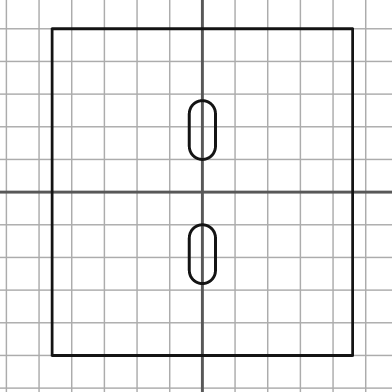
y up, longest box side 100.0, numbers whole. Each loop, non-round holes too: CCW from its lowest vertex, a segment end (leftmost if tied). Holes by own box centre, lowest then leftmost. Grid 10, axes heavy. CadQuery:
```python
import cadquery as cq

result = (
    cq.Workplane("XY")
    .moveTo(-46.0, -50.0)
    .lineTo(46.0, -50.0)
    .lineTo(46.0, 50.0)
    .lineTo(-46.0, 50.0)
    .close()
    .moveTo(-4.0, -24.0)
    .threePointArc((0.0, -28.0), (4.0, -24.0))
    .lineTo(4.0, -14.0)
    .threePointArc((0.0, -10.0), (-4.0, -14.0))
    .close()
    .moveTo(-4.0, 14.0)
    .threePointArc((0.0, 10.0), (4.0, 14.0))
    .lineTo(4.0, 24.0)
    .threePointArc((0.0, 28.0), (-4.0, 24.0))
    .close()
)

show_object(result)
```